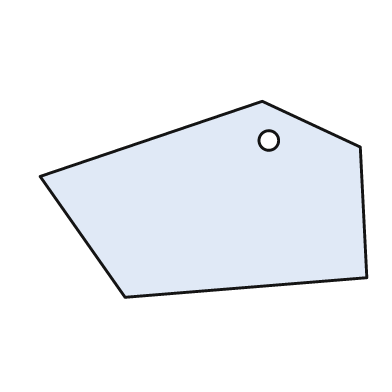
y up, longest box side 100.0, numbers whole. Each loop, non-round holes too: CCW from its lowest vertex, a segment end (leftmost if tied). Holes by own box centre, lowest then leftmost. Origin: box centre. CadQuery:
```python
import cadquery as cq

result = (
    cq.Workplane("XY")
    .moveTo(-24.0, -30.0)
    .lineTo(50.0, -24.0)
    .lineTo(48.0, 16.0)
    .lineTo(18.0, 30.0)
    .lineTo(-50.0, 7.0)
    .close()
    .moveTo(20.0, 18.0)
    .circle(3.0)
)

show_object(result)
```